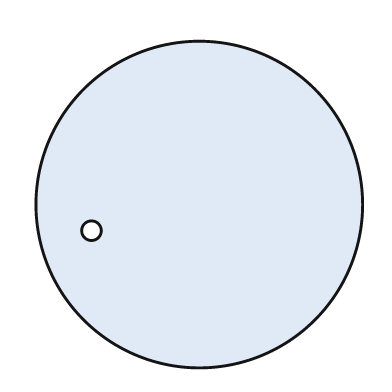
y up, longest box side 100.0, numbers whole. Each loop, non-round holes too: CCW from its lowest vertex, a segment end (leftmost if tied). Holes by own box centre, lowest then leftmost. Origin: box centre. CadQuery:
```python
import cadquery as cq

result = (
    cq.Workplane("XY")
    .moveTo(0.0, 0.0)
    .circle(50.0)
    .moveTo(-33.0, -8.0)
    .circle(3.0)
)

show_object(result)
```